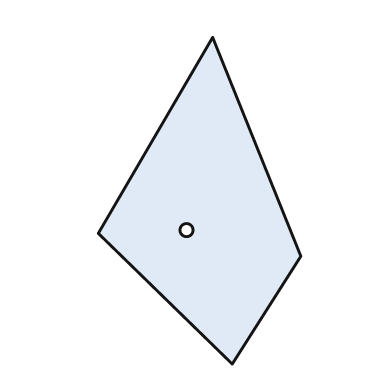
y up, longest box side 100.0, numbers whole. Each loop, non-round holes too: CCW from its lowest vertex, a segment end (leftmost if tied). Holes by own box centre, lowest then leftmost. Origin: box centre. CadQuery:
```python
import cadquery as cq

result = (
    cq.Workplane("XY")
    .moveTo(10.0, -50.0)
    .lineTo(31.0, -17.0)
    .lineTo(4.0, 50.0)
    .lineTo(-31.0, -10.0)
    .close()
    .moveTo(-4.0, -9.0)
    .circle(2.0)
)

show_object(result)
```